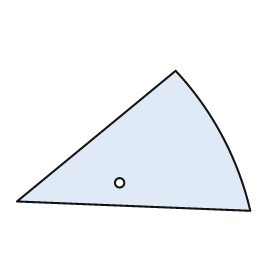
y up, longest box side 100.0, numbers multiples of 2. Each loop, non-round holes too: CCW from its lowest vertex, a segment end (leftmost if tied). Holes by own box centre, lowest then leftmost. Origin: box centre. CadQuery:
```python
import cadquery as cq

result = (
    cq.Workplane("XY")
    .moveTo(50.0, -30.0)
    .threePointArc((38.0, 2.0), (18.0, 30.0))
    .lineTo(-50.0, -26.0)
    .close()
    .moveTo(-6.0, -18.0)
    .circle(2.0)
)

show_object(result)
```